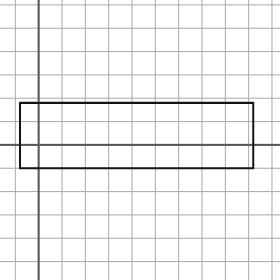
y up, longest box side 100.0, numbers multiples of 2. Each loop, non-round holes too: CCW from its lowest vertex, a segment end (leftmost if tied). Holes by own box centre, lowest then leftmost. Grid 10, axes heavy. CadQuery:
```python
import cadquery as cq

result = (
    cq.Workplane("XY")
    .moveTo(-8.0, -10.0)
    .lineTo(92.0, -10.0)
    .lineTo(92.0, 18.0)
    .lineTo(-8.0, 18.0)
    .close()
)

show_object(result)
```